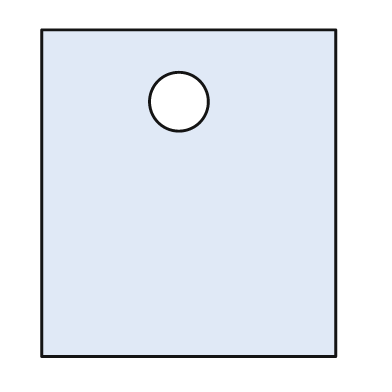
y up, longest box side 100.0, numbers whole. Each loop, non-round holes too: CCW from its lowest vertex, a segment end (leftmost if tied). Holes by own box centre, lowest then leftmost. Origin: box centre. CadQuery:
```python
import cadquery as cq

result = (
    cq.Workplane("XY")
    .moveTo(-45.0, -50.0)
    .lineTo(45.0, -50.0)
    .lineTo(45.0, 50.0)
    .lineTo(-45.0, 50.0)
    .close()
    .moveTo(-3.0, 28.0)
    .circle(9.0)
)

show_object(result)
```